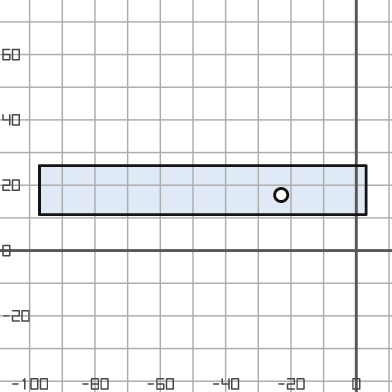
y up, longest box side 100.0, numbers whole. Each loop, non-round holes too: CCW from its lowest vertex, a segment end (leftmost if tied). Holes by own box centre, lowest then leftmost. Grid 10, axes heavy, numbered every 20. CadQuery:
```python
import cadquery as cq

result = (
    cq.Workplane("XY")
    .moveTo(-97.0, 11.0)
    .lineTo(3.0, 11.0)
    .lineTo(3.0, 26.0)
    .lineTo(-97.0, 26.0)
    .close()
    .moveTo(-23.0, 17.0)
    .circle(2.0)
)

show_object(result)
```